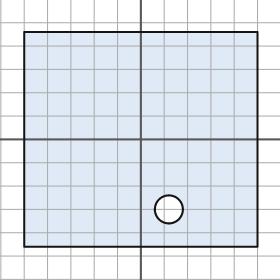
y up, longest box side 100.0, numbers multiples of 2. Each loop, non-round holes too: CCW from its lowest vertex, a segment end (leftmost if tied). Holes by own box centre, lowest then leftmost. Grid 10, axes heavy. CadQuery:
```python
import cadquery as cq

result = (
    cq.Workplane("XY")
    .moveTo(-50.0, -46.0)
    .lineTo(50.0, -46.0)
    .lineTo(50.0, 46.0)
    .lineTo(-50.0, 46.0)
    .close()
    .moveTo(12.0, -30.0)
    .circle(6.0)
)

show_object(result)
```